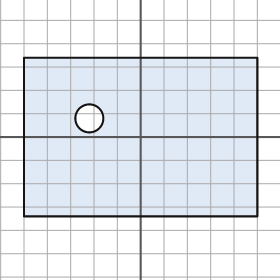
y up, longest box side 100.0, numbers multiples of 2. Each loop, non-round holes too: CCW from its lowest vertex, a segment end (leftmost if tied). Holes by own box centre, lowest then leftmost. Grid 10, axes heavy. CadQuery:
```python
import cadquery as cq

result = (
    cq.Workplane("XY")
    .moveTo(-50.0, -34.0)
    .lineTo(50.0, -34.0)
    .lineTo(50.0, 34.0)
    .lineTo(-50.0, 34.0)
    .close()
    .moveTo(-22.0, 8.0)
    .circle(6.0)
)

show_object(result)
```